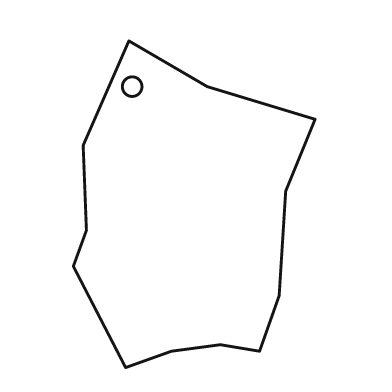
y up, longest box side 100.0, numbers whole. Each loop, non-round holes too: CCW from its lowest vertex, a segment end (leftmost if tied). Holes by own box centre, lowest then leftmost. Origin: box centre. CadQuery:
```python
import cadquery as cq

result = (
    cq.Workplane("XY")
    .moveTo(-21.0, -50.0)
    .lineTo(-7.0, -45.0)
    .lineTo(8.0, -43.0)
    .lineTo(20.0, -45.0)
    .lineTo(26.0, -28.0)
    .lineTo(28.0, 4.0)
    .lineTo(37.0, 26.0)
    .lineTo(4.0, 36.0)
    .lineTo(-20.0, 50.0)
    .lineTo(-34.0, 18.0)
    .lineTo(-33.0, -8.0)
    .lineTo(-37.0, -19.0)
    .close()
    .moveTo(-19.0, 36.0)
    .circle(3.0)
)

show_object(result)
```